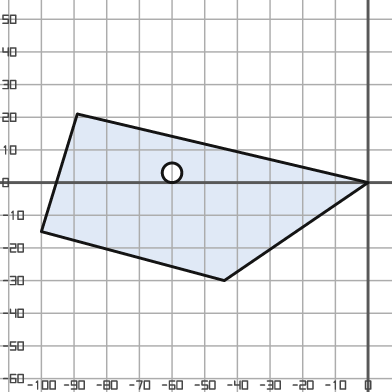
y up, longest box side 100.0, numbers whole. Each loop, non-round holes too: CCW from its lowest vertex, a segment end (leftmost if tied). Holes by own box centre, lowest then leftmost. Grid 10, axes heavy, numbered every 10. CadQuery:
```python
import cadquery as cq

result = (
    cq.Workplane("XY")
    .moveTo(-44.0, -30.0)
    .lineTo(0.0, 0.0)
    .lineTo(-89.0, 21.0)
    .lineTo(-100.0, -15.0)
    .close()
    .moveTo(-60.0, 3.0)
    .circle(3.0)
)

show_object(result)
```